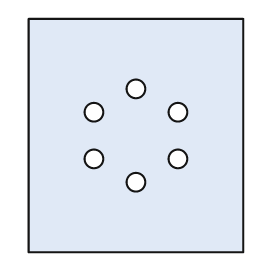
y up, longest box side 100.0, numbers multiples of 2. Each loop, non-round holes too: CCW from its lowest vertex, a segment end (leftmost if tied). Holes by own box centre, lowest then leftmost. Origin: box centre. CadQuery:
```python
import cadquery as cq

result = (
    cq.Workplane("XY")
    .moveTo(-46.0, -50.0)
    .lineTo(46.0, -50.0)
    .lineTo(46.0, 50.0)
    .lineTo(-46.0, 50.0)
    .close()
    .moveTo(0.0, -20.0)
    .circle(4.0)
    .moveTo(-18.0, -10.0)
    .circle(4.0)
    .moveTo(18.0, -10.0)
    .circle(4.0)
    .moveTo(-18.0, 10.0)
    .circle(4.0)
    .moveTo(18.0, 10.0)
    .circle(4.0)
    .moveTo(0.0, 20.0)
    .circle(4.0)
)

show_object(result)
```